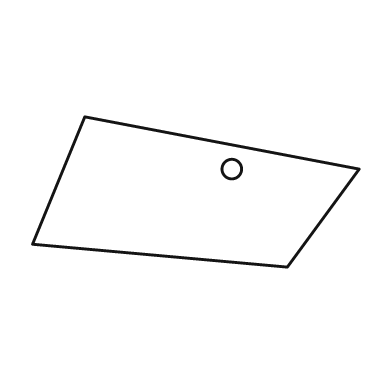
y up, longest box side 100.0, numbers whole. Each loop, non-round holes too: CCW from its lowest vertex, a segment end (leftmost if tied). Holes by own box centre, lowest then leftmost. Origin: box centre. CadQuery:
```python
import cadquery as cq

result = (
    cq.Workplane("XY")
    .moveTo(28.0, -23.0)
    .lineTo(50.0, 7.0)
    .lineTo(-34.0, 23.0)
    .lineTo(-50.0, -16.0)
    .close()
    .moveTo(11.0, 7.0)
    .circle(3.0)
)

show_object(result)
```